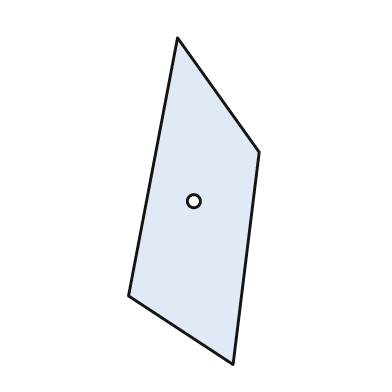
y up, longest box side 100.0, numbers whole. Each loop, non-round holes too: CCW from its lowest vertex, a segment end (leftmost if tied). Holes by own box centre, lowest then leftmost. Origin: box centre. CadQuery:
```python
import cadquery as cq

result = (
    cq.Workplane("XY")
    .moveTo(12.0, -50.0)
    .lineTo(20.0, 15.0)
    .lineTo(-5.0, 50.0)
    .lineTo(-20.0, -29.0)
    .close()
    .moveTo(0.0, 0.0)
    .circle(2.0)
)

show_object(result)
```